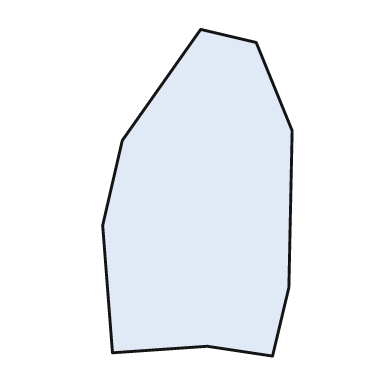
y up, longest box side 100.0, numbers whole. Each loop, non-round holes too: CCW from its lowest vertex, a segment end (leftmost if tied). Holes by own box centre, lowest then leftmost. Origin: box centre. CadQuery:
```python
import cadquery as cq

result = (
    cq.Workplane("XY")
    .moveTo(23.0, -50.0)
    .lineTo(28.0, -29.0)
    .lineTo(29.0, 19.0)
    .lineTo(18.0, 46.0)
    .lineTo(1.0, 50.0)
    .lineTo(-23.0, 16.0)
    .lineTo(-29.0, -10.0)
    .lineTo(-26.0, -49.0)
    .lineTo(3.0, -47.0)
    .close()
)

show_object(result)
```